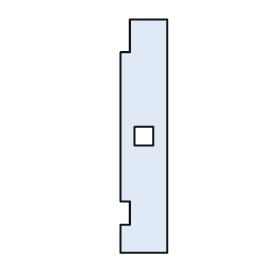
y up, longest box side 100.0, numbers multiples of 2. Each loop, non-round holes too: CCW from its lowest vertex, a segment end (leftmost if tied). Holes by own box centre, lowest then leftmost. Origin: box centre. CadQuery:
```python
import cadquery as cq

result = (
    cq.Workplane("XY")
    .moveTo(-10.0, -50.0)
    .lineTo(10.0, -50.0)
    .lineTo(10.0, 50.0)
    .lineTo(-6.0, 50.0)
    .lineTo(-6.0, 36.0)
    .lineTo(-10.0, 36.0)
    .lineTo(-10.0, -28.0)
    .lineTo(-6.0, -28.0)
    .lineTo(-6.0, -38.0)
    .lineTo(-10.0, -38.0)
    .close()
    .moveTo(-4.0, -4.0)
    .lineTo(4.0, -4.0)
    .lineTo(4.0, 4.0)
    .lineTo(-4.0, 4.0)
    .close()
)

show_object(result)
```